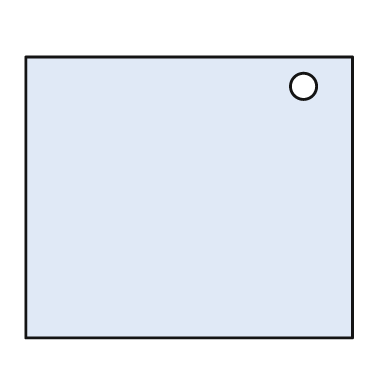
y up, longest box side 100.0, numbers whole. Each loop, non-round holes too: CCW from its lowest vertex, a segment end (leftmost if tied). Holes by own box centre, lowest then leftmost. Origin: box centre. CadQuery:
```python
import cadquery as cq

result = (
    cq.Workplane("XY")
    .moveTo(-50.0, -43.0)
    .lineTo(50.0, -43.0)
    .lineTo(50.0, 43.0)
    .lineTo(-50.0, 43.0)
    .close()
    .moveTo(35.0, 34.0)
    .circle(4.0)
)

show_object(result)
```